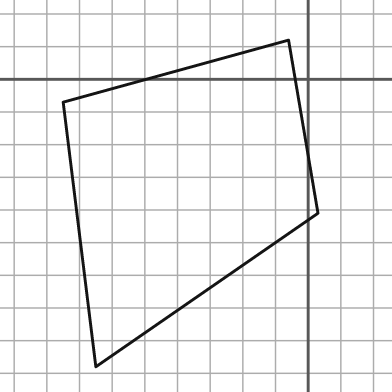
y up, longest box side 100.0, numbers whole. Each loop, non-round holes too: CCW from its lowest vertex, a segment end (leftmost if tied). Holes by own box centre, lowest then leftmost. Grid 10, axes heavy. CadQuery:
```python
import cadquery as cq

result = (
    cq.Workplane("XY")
    .moveTo(-65.0, -88.0)
    .lineTo(3.0, -41.0)
    .lineTo(-6.0, 12.0)
    .lineTo(-75.0, -7.0)
    .close()
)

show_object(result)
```